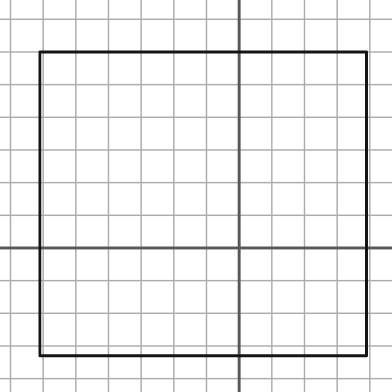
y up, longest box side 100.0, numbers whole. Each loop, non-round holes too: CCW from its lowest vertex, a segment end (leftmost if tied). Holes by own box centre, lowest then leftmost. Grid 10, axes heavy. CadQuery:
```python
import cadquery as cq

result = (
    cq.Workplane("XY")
    .moveTo(-61.0, -33.0)
    .lineTo(39.0, -33.0)
    .lineTo(39.0, 60.0)
    .lineTo(-61.0, 60.0)
    .close()
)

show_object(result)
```